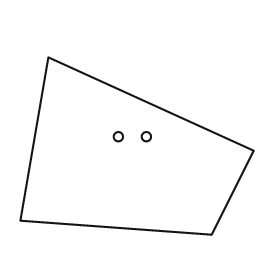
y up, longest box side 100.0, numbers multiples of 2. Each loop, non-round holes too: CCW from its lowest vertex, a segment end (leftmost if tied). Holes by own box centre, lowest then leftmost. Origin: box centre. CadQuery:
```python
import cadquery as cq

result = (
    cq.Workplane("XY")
    .moveTo(32.0, -38.0)
    .lineTo(50.0, -2.0)
    .lineTo(-38.0, 38.0)
    .lineTo(-50.0, -32.0)
    .close()
    .moveTo(-8.0, 4.0)
    .circle(2.0)
    .moveTo(4.0, 4.0)
    .circle(2.0)
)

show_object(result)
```